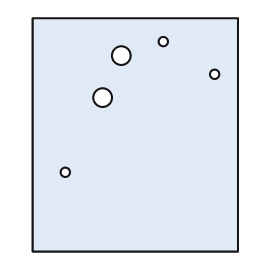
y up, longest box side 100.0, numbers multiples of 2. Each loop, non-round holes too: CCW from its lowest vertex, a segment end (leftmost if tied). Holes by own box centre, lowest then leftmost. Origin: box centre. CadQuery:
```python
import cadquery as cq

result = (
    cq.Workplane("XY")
    .moveTo(-44.0, -50.0)
    .lineTo(44.0, -50.0)
    .lineTo(44.0, 50.0)
    .lineTo(-44.0, 50.0)
    .close()
    .moveTo(-30.0, -16.0)
    .circle(2.0)
    .moveTo(-14.0, 16.0)
    .circle(4.0)
    .moveTo(34.0, 26.0)
    .circle(2.0)
    .moveTo(-6.0, 34.0)
    .circle(4.0)
    .moveTo(12.0, 40.0)
    .circle(2.0)
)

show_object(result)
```